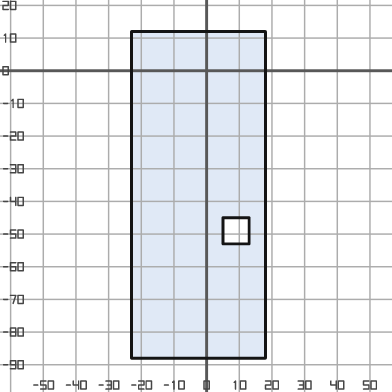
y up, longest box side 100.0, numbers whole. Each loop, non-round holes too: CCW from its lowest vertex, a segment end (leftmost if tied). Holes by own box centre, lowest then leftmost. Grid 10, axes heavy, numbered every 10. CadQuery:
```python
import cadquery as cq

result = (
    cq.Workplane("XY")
    .moveTo(-23.0, -88.0)
    .lineTo(18.0, -88.0)
    .lineTo(18.0, 12.0)
    .lineTo(-23.0, 12.0)
    .close()
    .moveTo(5.0, -53.0)
    .lineTo(13.0, -53.0)
    .lineTo(13.0, -45.0)
    .lineTo(5.0, -45.0)
    .close()
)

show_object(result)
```